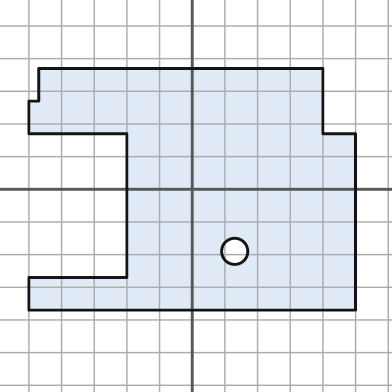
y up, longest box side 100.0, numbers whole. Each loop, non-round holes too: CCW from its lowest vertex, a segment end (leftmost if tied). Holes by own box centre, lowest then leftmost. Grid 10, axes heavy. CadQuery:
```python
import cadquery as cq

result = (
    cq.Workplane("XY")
    .moveTo(-50.0, -37.0)
    .lineTo(50.0, -37.0)
    .lineTo(50.0, 17.0)
    .lineTo(40.0, 17.0)
    .lineTo(40.0, 37.0)
    .lineTo(-47.0, 37.0)
    .lineTo(-47.0, 27.0)
    .lineTo(-50.0, 27.0)
    .lineTo(-50.0, 17.0)
    .lineTo(-20.0, 17.0)
    .lineTo(-20.0, -27.0)
    .lineTo(-50.0, -27.0)
    .close()
    .moveTo(13.0, -19.0)
    .circle(4.0)
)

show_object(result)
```